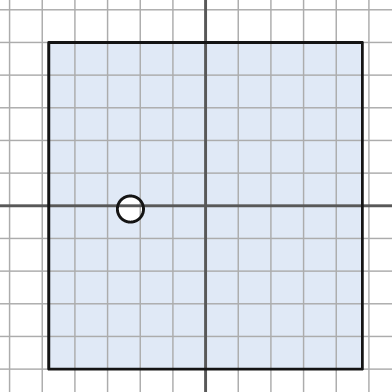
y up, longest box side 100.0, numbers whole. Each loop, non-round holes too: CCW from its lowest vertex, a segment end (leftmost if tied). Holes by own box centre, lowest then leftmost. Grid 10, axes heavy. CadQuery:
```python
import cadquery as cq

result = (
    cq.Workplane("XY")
    .moveTo(-48.0, -50.0)
    .lineTo(48.0, -50.0)
    .lineTo(48.0, 50.0)
    .lineTo(-48.0, 50.0)
    .close()
    .moveTo(-23.0, -1.0)
    .circle(4.0)
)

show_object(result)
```